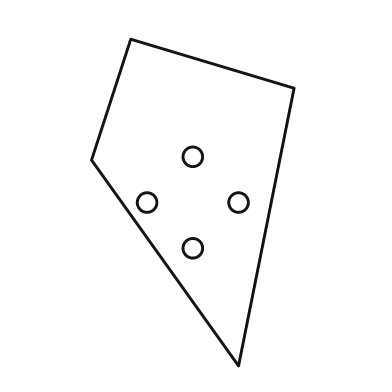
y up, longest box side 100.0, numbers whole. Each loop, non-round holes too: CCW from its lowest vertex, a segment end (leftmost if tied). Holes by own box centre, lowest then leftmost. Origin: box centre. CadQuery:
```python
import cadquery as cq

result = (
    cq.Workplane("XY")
    .moveTo(14.0, -50.0)
    .lineTo(31.0, 35.0)
    .lineTo(-19.0, 50.0)
    .lineTo(-31.0, 13.0)
    .close()
    .moveTo(0.0, -14.0)
    .circle(3.0)
    .moveTo(-14.0, 0.0)
    .circle(3.0)
    .moveTo(14.0, 0.0)
    .circle(3.0)
    .moveTo(0.0, 14.0)
    .circle(3.0)
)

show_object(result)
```